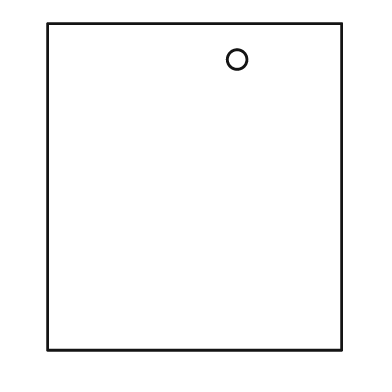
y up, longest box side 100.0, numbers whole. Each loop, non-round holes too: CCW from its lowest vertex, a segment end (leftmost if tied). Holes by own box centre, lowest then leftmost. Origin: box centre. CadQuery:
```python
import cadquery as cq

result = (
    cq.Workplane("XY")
    .moveTo(-45.0, -50.0)
    .lineTo(45.0, -50.0)
    .lineTo(45.0, 50.0)
    .lineTo(-45.0, 50.0)
    .close()
    .moveTo(13.0, 39.0)
    .circle(3.0)
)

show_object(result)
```